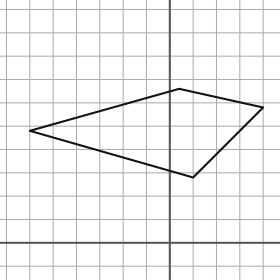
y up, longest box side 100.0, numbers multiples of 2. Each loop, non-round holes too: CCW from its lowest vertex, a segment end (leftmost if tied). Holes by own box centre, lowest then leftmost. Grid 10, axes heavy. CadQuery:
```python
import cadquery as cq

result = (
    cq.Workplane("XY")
    .moveTo(10.0, 28.0)
    .lineTo(40.0, 58.0)
    .lineTo(4.0, 66.0)
    .lineTo(-60.0, 48.0)
    .close()
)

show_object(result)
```